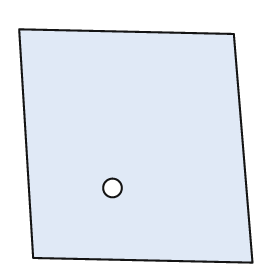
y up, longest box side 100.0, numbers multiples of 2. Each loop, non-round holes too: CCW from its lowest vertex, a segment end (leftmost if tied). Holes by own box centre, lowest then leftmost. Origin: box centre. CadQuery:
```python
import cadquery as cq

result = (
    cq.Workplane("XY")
    .moveTo(50.0, -50.0)
    .lineTo(42.0, 48.0)
    .lineTo(-50.0, 50.0)
    .lineTo(-44.0, -48.0)
    .close()
    .moveTo(-10.0, -18.0)
    .circle(4.0)
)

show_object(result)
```